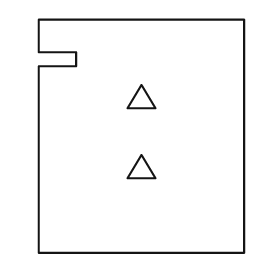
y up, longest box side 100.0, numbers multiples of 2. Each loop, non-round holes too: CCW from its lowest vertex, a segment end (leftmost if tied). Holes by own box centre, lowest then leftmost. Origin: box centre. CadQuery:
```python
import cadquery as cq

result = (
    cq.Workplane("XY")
    .moveTo(-44.0, -50.0)
    .lineTo(44.0, -50.0)
    .lineTo(44.0, 50.0)
    .lineTo(-44.0, 50.0)
    .lineTo(-44.0, 36.0)
    .lineTo(-28.0, 36.0)
    .lineTo(-28.0, 30.0)
    .lineTo(-44.0, 30.0)
    .close()
    .moveTo(-6.0, -18.0)
    .lineTo(6.0, -18.0)
    .lineTo(0.0, -8.0)
    .close()
    .moveTo(-6.0, 12.0)
    .lineTo(6.0, 12.0)
    .lineTo(0.0, 22.0)
    .close()
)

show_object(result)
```